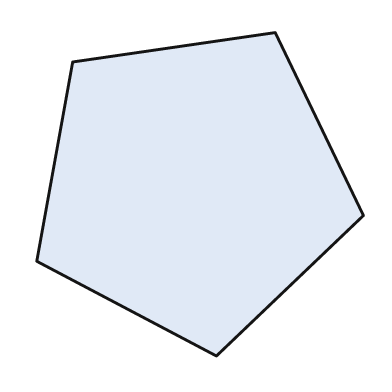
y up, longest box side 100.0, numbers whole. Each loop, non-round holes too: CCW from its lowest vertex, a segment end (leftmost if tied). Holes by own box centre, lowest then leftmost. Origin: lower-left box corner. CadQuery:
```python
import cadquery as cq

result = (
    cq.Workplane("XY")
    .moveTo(55.0, 0.0)
    .lineTo(100.0, 43.0)
    .lineTo(73.0, 99.0)
    .lineTo(11.0, 90.0)
    .lineTo(0.0, 29.0)
    .close()
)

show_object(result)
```